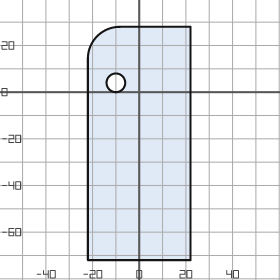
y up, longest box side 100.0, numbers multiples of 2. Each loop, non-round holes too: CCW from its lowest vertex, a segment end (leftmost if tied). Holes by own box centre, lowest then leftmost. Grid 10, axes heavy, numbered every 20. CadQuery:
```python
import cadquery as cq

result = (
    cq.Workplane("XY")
    .moveTo(-22.0, -72.0)
    .lineTo(22.0, -72.0)
    .lineTo(22.0, 28.0)
    .lineTo(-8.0, 28.0)
    .threePointArc((-18.0, 24.0), (-22.0, 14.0))
    .close()
    .moveTo(-10.0, 4.0)
    .circle(4.0)
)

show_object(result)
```